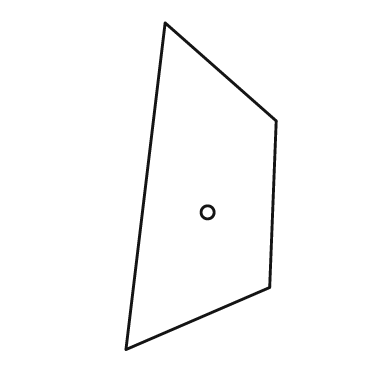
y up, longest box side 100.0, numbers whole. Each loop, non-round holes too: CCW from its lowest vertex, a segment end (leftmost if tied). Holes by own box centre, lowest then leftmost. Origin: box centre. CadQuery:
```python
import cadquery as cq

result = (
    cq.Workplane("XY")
    .moveTo(-23.0, -50.0)
    .lineTo(21.0, -31.0)
    .lineTo(23.0, 20.0)
    .lineTo(-11.0, 50.0)
    .close()
    .moveTo(2.0, -8.0)
    .circle(2.0)
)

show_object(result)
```